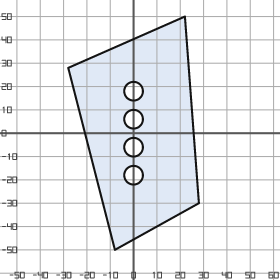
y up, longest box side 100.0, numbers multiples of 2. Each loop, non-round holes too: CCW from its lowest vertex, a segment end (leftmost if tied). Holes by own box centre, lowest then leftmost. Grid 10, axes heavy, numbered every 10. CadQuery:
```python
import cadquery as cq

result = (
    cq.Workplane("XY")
    .moveTo(-8.0, -50.0)
    .lineTo(28.0, -30.0)
    .lineTo(22.0, 50.0)
    .lineTo(-28.0, 28.0)
    .close()
    .moveTo(0.0, -18.0)
    .circle(4.0)
    .moveTo(0.0, -6.0)
    .circle(4.0)
    .moveTo(0.0, 6.0)
    .circle(4.0)
    .moveTo(0.0, 18.0)
    .circle(4.0)
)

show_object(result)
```